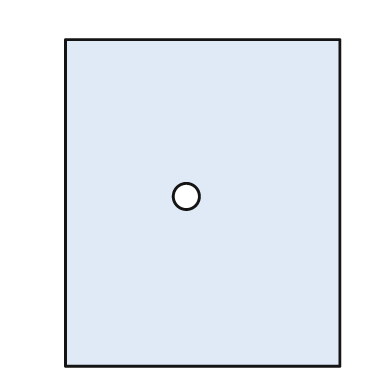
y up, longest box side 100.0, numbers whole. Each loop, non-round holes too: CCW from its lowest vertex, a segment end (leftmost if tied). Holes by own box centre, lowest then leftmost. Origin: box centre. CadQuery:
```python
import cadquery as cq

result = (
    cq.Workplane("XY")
    .moveTo(-42.0, -50.0)
    .lineTo(42.0, -50.0)
    .lineTo(42.0, 50.0)
    .lineTo(-42.0, 50.0)
    .close()
    .moveTo(-5.0, 2.0)
    .circle(4.0)
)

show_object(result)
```